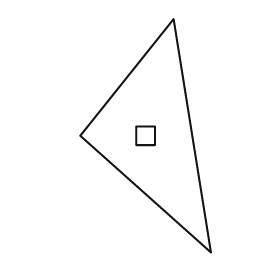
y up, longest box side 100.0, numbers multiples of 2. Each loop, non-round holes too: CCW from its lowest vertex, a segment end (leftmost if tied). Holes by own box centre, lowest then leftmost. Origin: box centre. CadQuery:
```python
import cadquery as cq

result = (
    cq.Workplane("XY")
    .moveTo(28.0, -50.0)
    .lineTo(12.0, 50.0)
    .lineTo(-28.0, 0.0)
    .close()
    .moveTo(-4.0, -4.0)
    .lineTo(4.0, -4.0)
    .lineTo(4.0, 4.0)
    .lineTo(-4.0, 4.0)
    .close()
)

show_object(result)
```